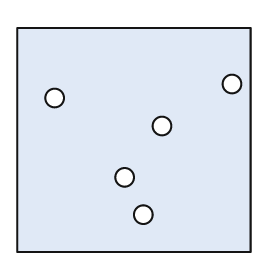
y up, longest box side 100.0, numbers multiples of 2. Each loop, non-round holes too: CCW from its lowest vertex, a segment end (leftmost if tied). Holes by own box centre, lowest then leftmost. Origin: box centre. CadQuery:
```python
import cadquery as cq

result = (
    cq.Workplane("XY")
    .moveTo(-50.0, -48.0)
    .lineTo(50.0, -48.0)
    .lineTo(50.0, 48.0)
    .lineTo(-50.0, 48.0)
    .close()
    .moveTo(4.0, -32.0)
    .circle(4.0)
    .moveTo(-4.0, -16.0)
    .circle(4.0)
    .moveTo(12.0, 6.0)
    .circle(4.0)
    .moveTo(-34.0, 18.0)
    .circle(4.0)
    .moveTo(42.0, 24.0)
    .circle(4.0)
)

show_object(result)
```